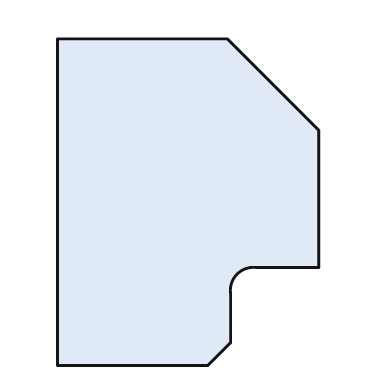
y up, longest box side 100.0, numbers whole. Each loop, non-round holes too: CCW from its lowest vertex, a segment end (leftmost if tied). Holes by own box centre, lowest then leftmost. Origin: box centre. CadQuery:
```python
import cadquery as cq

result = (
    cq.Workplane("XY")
    .moveTo(-40.0, -50.0)
    .lineTo(6.0, -50.0)
    .lineTo(13.0, -43.0)
    .lineTo(13.0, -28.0)
    .threePointArc((15.0, -22.0), (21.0, -20.0))
    .lineTo(40.0, -20.0)
    .lineTo(40.0, 22.0)
    .lineTo(12.0, 50.0)
    .lineTo(-40.0, 50.0)
    .close()
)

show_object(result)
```